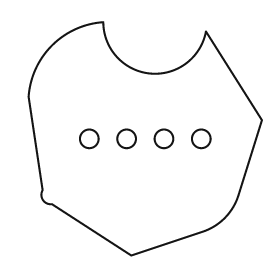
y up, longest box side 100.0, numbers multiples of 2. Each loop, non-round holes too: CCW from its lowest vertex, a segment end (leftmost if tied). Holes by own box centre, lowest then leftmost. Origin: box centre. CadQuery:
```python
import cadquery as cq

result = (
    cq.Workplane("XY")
    .moveTo(-6.0, -50.0)
    .lineTo(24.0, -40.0)
    .threePointArc((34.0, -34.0), (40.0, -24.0))
    .lineTo(50.0, 8.0)
    .lineTo(26.0, 46.0)
    .threePointArc((2.0, 28.0), (-18.0, 50.0))
    .threePointArc((-40.0, 40.0), (-50.0, 18.0))
    .lineTo(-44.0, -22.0)
    .threePointArc((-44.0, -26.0), (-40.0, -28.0))
    .close()
    .moveTo(-24.0, 0.0)
    .circle(4.0)
    .moveTo(-8.0, 0.0)
    .circle(4.0)
    .moveTo(8.0, 0.0)
    .circle(4.0)
    .moveTo(24.0, 0.0)
    .circle(4.0)
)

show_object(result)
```